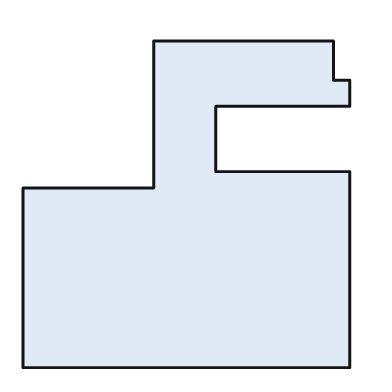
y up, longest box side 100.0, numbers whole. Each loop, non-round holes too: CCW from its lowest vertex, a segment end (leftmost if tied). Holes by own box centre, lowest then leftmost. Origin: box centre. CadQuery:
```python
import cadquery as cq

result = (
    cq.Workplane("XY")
    .moveTo(-50.0, -50.0)
    .lineTo(50.0, -50.0)
    .lineTo(50.0, 10.0)
    .lineTo(9.0, 10.0)
    .lineTo(9.0, 30.0)
    .lineTo(50.0, 30.0)
    .lineTo(50.0, 38.0)
    .lineTo(45.0, 38.0)
    .lineTo(45.0, 50.0)
    .lineTo(-10.0, 50.0)
    .lineTo(-10.0, 5.0)
    .lineTo(-50.0, 5.0)
    .close()
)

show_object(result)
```